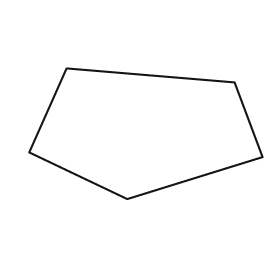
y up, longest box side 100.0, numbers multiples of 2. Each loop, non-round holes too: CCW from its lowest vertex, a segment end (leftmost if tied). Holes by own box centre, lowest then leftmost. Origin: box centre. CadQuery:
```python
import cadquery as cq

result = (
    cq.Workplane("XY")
    .moveTo(-8.0, -28.0)
    .lineTo(50.0, -10.0)
    .lineTo(38.0, 22.0)
    .lineTo(-34.0, 28.0)
    .lineTo(-50.0, -8.0)
    .close()
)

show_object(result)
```